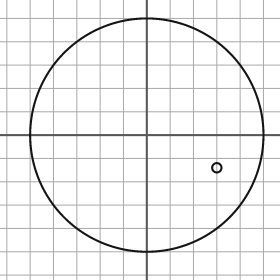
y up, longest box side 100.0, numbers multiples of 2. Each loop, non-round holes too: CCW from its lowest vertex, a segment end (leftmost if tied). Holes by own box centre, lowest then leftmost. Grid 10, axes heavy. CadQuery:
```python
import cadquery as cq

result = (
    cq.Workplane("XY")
    .moveTo(0.0, 0.0)
    .circle(50.0)
    .moveTo(30.0, -14.0)
    .circle(2.0)
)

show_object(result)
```